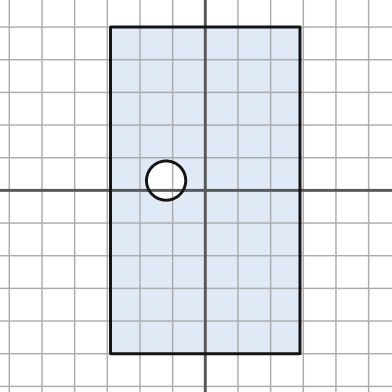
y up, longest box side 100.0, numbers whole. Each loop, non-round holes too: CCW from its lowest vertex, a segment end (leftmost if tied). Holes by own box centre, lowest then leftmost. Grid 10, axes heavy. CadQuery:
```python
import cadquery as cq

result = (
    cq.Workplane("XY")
    .moveTo(-29.0, -50.0)
    .lineTo(29.0, -50.0)
    .lineTo(29.0, 50.0)
    .lineTo(-29.0, 50.0)
    .close()
    .moveTo(-12.0, 3.0)
    .circle(6.0)
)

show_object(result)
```